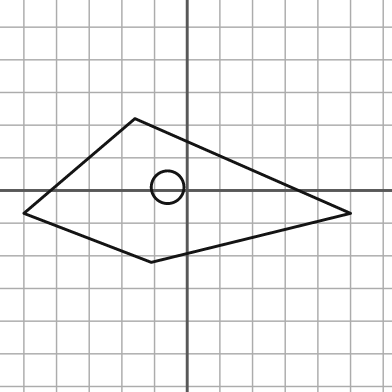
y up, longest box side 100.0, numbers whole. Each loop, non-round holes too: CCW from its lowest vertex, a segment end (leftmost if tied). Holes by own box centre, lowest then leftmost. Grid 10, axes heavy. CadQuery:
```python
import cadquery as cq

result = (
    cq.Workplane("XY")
    .moveTo(-11.0, -22.0)
    .lineTo(50.0, -7.0)
    .lineTo(-16.0, 22.0)
    .lineTo(-50.0, -7.0)
    .close()
    .moveTo(-6.0, 1.0)
    .circle(5.0)
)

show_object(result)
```